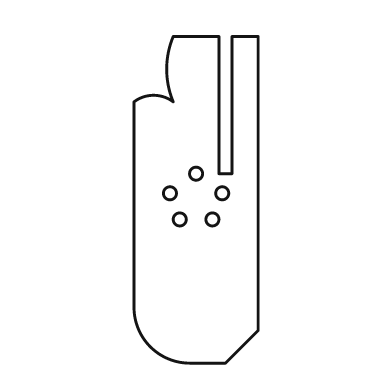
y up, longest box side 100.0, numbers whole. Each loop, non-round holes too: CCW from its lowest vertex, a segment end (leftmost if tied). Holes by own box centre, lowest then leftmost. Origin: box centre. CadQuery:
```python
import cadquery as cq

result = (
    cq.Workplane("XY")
    .moveTo(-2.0, -50.0)
    .lineTo(9.0, -50.0)
    .lineTo(19.0, -40.0)
    .lineTo(19.0, 50.0)
    .lineTo(11.0, 50.0)
    .lineTo(11.0, 8.0)
    .lineTo(7.0, 8.0)
    .lineTo(7.0, 50.0)
    .lineTo(-7.0, 50.0)
    .threePointArc((-9.0, 40.0), (-7.0, 30.0))
    .threePointArc((-13.0, 32.0), (-19.0, 30.0))
    .lineTo(-19.0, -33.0)
    .threePointArc((-14.0, -45.0), (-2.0, -50.0))
    .close()
    .moveTo(-5.0, -6.0)
    .circle(2.0)
    .moveTo(5.0, -6.0)
    .circle(2.0)
    .moveTo(-8.0, 2.0)
    .circle(2.0)
    .moveTo(8.0, 2.0)
    .circle(2.0)
    .moveTo(0.0, 8.0)
    .circle(2.0)
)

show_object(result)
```